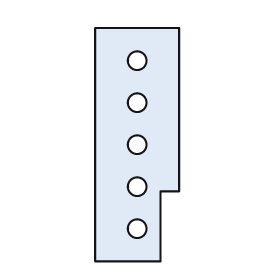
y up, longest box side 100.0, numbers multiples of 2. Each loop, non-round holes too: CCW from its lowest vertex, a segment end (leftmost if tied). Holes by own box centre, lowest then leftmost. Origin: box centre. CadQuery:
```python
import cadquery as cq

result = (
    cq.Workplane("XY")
    .moveTo(-18.0, -50.0)
    .lineTo(10.0, -50.0)
    .lineTo(10.0, -20.0)
    .lineTo(18.0, -20.0)
    .lineTo(18.0, 50.0)
    .lineTo(-18.0, 50.0)
    .close()
    .moveTo(0.0, -36.0)
    .circle(4.0)
    .moveTo(0.0, -18.0)
    .circle(4.0)
    .moveTo(0.0, 0.0)
    .circle(4.0)
    .moveTo(0.0, 18.0)
    .circle(4.0)
    .moveTo(0.0, 36.0)
    .circle(4.0)
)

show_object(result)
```